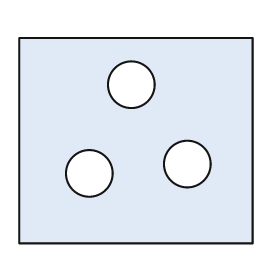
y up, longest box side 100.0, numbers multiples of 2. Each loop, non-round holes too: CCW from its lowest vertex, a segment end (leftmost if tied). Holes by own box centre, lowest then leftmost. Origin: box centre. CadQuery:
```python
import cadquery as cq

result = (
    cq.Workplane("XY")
    .moveTo(-50.0, -44.0)
    .lineTo(50.0, -44.0)
    .lineTo(50.0, 44.0)
    .lineTo(-50.0, 44.0)
    .close()
    .moveTo(-20.0, -14.0)
    .circle(10.0)
    .moveTo(22.0, -10.0)
    .circle(10.0)
    .moveTo(-2.0, 24.0)
    .circle(10.0)
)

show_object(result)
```